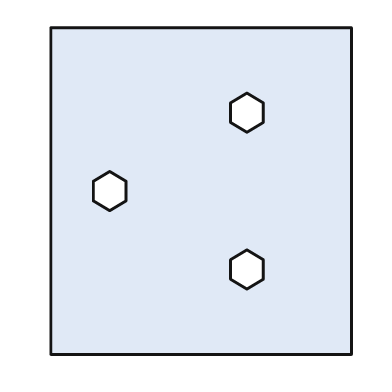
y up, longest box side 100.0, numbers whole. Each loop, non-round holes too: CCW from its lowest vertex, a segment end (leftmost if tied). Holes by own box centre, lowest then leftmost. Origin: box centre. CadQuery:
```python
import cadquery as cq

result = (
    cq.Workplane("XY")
    .moveTo(-46.0, -50.0)
    .lineTo(46.0, -50.0)
    .lineTo(46.0, 50.0)
    .lineTo(-46.0, 50.0)
    .close()
    .moveTo(14.0, -30.0)
    .lineTo(19.0, -27.0)
    .lineTo(19.0, -21.0)
    .lineTo(14.0, -18.0)
    .lineTo(9.0, -21.0)
    .lineTo(9.0, -27.0)
    .close()
    .moveTo(-28.0, -6.0)
    .lineTo(-23.0, -3.0)
    .lineTo(-23.0, 3.0)
    .lineTo(-28.0, 6.0)
    .lineTo(-33.0, 3.0)
    .lineTo(-33.0, -3.0)
    .close()
    .moveTo(14.0, 18.0)
    .lineTo(19.0, 21.0)
    .lineTo(19.0, 27.0)
    .lineTo(14.0, 30.0)
    .lineTo(9.0, 27.0)
    .lineTo(9.0, 21.0)
    .close()
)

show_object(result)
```